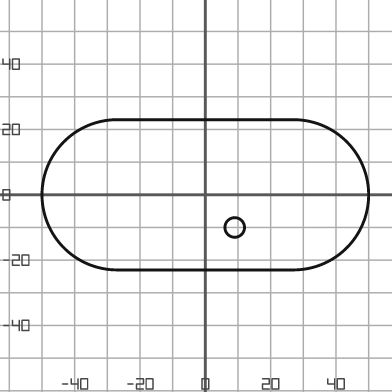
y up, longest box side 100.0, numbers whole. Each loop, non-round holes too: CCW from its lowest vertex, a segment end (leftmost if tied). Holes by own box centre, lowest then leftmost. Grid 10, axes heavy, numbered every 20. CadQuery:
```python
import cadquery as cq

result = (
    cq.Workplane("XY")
    .moveTo(-27.0, -23.0)
    .lineTo(27.0, -23.0)
    .threePointArc((50.0, 0.0), (27.0, 23.0))
    .lineTo(-27.0, 23.0)
    .threePointArc((-50.0, 0.0), (-27.0, -23.0))
    .close()
    .moveTo(9.0, -10.0)
    .circle(3.0)
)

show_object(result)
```